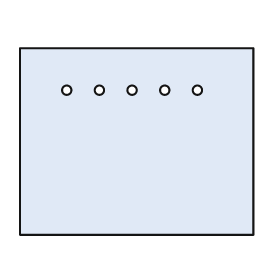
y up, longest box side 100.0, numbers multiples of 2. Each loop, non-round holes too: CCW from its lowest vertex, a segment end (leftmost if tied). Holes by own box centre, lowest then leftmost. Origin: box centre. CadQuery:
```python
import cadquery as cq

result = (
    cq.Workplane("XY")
    .moveTo(-50.0, -40.0)
    .lineTo(50.0, -40.0)
    .lineTo(50.0, 40.0)
    .lineTo(-50.0, 40.0)
    .close()
    .moveTo(-30.0, 22.0)
    .circle(2.0)
    .moveTo(-16.0, 22.0)
    .circle(2.0)
    .moveTo(-2.0, 22.0)
    .circle(2.0)
    .moveTo(12.0, 22.0)
    .circle(2.0)
    .moveTo(26.0, 22.0)
    .circle(2.0)
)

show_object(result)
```